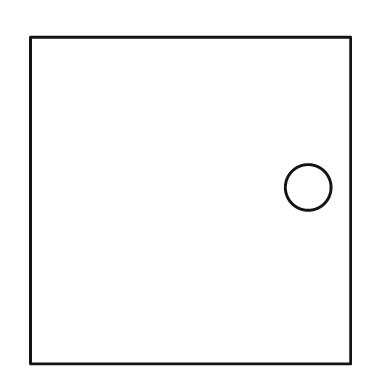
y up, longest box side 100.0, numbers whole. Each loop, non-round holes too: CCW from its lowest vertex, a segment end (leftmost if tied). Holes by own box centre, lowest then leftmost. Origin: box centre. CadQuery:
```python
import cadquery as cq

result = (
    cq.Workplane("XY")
    .moveTo(-49.0, -50.0)
    .lineTo(49.0, -50.0)
    .lineTo(49.0, 50.0)
    .lineTo(-49.0, 50.0)
    .close()
    .moveTo(36.0, 4.0)
    .circle(7.0)
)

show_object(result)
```